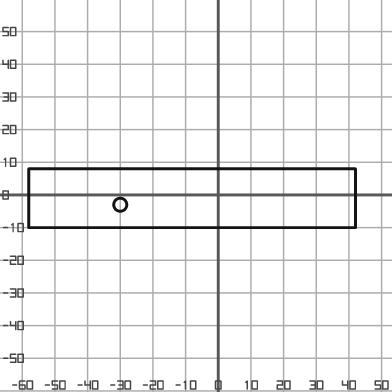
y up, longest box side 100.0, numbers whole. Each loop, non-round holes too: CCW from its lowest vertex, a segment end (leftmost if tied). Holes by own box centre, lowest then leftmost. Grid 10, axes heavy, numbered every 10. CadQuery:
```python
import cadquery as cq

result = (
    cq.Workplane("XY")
    .moveTo(-58.0, -10.0)
    .lineTo(42.0, -10.0)
    .lineTo(42.0, 8.0)
    .lineTo(-58.0, 8.0)
    .close()
    .moveTo(-30.0, -3.0)
    .circle(2.0)
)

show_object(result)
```